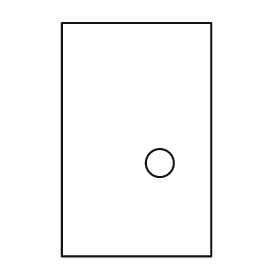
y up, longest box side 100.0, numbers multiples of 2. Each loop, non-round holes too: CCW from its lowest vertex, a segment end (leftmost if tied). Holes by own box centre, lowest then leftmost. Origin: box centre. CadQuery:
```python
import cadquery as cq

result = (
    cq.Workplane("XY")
    .moveTo(-32.0, -50.0)
    .lineTo(32.0, -50.0)
    .lineTo(32.0, 50.0)
    .lineTo(-32.0, 50.0)
    .close()
    .moveTo(10.0, -10.0)
    .circle(6.0)
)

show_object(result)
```